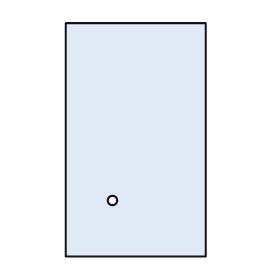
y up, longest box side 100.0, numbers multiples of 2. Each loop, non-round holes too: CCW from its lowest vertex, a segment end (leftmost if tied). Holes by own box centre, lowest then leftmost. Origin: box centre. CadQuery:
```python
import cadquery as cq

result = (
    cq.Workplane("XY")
    .moveTo(-30.0, -50.0)
    .lineTo(30.0, -50.0)
    .lineTo(30.0, 50.0)
    .lineTo(-30.0, 50.0)
    .close()
    .moveTo(-10.0, -26.0)
    .circle(2.0)
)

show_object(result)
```